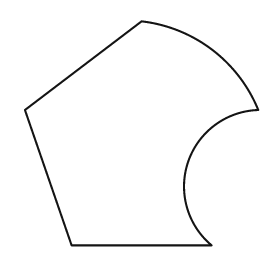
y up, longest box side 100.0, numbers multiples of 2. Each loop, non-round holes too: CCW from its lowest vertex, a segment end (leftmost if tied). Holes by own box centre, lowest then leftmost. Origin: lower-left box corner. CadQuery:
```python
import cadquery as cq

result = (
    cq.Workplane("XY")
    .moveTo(20.0, 0.0)
    .lineTo(80.0, 0.0)
    .threePointArc((70.0, 36.0), (100.0, 58.0))
    .threePointArc((80.0, 84.0), (50.0, 96.0))
    .lineTo(0.0, 58.0)
    .close()
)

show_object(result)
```